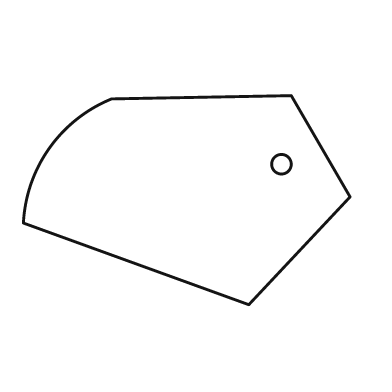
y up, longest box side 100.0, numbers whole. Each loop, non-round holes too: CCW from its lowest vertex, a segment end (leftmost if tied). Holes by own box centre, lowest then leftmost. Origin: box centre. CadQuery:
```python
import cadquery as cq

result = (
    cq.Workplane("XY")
    .moveTo(19.0, -32.0)
    .lineTo(50.0, 1.0)
    .lineTo(32.0, 32.0)
    .lineTo(-23.0, 31.0)
    .threePointArc((-42.0, 16.0), (-50.0, -7.0))
    .close()
    .moveTo(29.0, 11.0)
    .circle(3.0)
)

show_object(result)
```